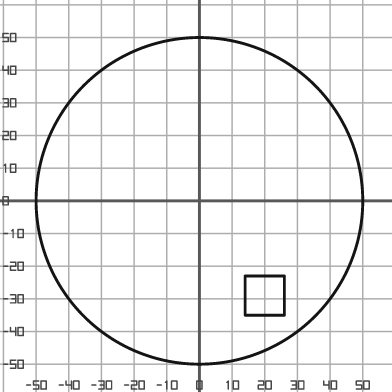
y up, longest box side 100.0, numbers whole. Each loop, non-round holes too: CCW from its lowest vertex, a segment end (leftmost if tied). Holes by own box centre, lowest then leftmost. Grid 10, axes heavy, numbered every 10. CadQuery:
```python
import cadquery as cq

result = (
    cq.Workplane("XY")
    .moveTo(0.0, 0.0)
    .circle(50.0)
    .moveTo(14.0, -35.0)
    .lineTo(26.0, -35.0)
    .lineTo(26.0, -23.0)
    .lineTo(14.0, -23.0)
    .close()
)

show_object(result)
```